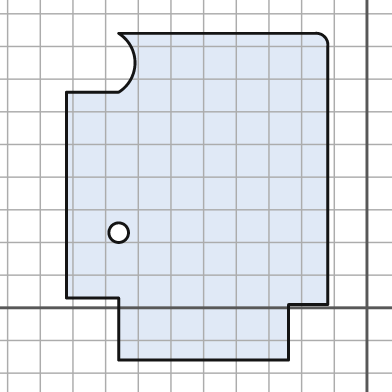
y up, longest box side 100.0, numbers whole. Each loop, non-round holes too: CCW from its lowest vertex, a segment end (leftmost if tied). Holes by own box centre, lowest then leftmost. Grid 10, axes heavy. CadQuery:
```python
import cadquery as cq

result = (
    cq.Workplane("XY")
    .moveTo(-76.0, -16.0)
    .lineTo(-24.0, -16.0)
    .lineTo(-24.0, 1.0)
    .lineTo(-12.0, 1.0)
    .lineTo(-12.0, 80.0)
    .threePointArc((-13.0, 83.0), (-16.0, 84.0))
    .lineTo(-76.0, 84.0)
    .threePointArc((-71.0, 75.0), (-76.0, 66.0))
    .lineTo(-92.0, 66.0)
    .lineTo(-92.0, 3.0)
    .lineTo(-76.0, 3.0)
    .close()
    .moveTo(-76.0, 23.0)
    .circle(3.0)
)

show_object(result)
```